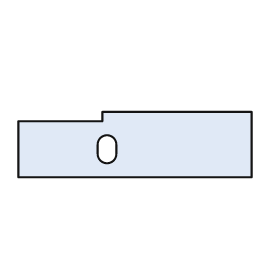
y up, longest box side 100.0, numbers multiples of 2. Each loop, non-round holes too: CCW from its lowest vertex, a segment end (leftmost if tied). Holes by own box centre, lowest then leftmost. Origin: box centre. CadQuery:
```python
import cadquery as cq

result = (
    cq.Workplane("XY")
    .moveTo(-50.0, -14.0)
    .lineTo(50.0, -14.0)
    .lineTo(50.0, 14.0)
    .lineTo(-14.0, 14.0)
    .lineTo(-14.0, 10.0)
    .lineTo(-50.0, 10.0)
    .close()
    .moveTo(-16.0, -4.0)
    .threePointArc((-12.0, -8.0), (-8.0, -4.0))
    .lineTo(-8.0, 0.0)
    .threePointArc((-12.0, 4.0), (-16.0, 0.0))
    .close()
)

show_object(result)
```